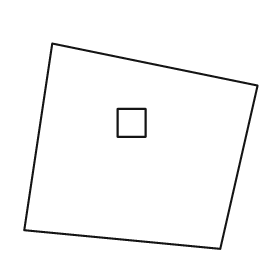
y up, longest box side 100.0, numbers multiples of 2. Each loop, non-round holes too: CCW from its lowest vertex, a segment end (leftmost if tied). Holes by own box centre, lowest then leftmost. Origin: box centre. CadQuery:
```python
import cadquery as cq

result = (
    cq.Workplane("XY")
    .moveTo(34.0, -44.0)
    .lineTo(50.0, 26.0)
    .lineTo(-38.0, 44.0)
    .lineTo(-50.0, -36.0)
    .close()
    .moveTo(-10.0, 4.0)
    .lineTo(2.0, 4.0)
    .lineTo(2.0, 16.0)
    .lineTo(-10.0, 16.0)
    .close()
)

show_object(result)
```